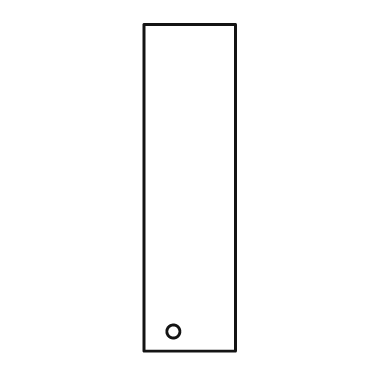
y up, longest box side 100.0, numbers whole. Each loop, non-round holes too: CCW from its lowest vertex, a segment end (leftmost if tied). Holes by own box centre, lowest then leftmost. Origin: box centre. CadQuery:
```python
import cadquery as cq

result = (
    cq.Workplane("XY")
    .moveTo(-14.0, -50.0)
    .lineTo(14.0, -50.0)
    .lineTo(14.0, 50.0)
    .lineTo(-14.0, 50.0)
    .close()
    .moveTo(-5.0, -44.0)
    .circle(2.0)
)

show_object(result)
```